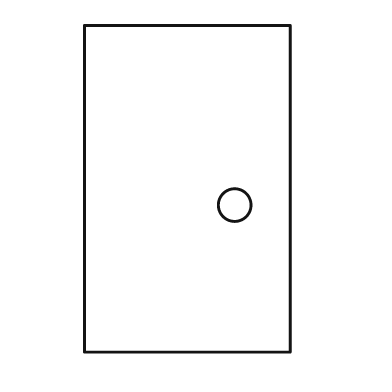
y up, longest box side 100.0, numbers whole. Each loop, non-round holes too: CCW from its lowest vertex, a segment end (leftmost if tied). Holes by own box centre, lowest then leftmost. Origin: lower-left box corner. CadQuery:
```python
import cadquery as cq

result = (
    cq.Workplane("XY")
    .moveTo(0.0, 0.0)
    .lineTo(63.0, 0.0)
    .lineTo(63.0, 100.0)
    .lineTo(0.0, 100.0)
    .close()
    .moveTo(46.0, 45.0)
    .circle(5.0)
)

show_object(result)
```